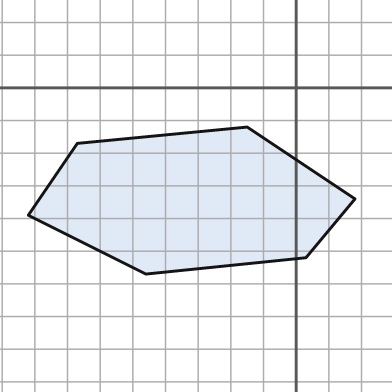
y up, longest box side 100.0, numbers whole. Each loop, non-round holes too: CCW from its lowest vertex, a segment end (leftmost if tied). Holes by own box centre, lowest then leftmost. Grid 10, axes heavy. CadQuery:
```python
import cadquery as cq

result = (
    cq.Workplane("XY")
    .moveTo(-46.0, -57.0)
    .lineTo(3.0, -52.0)
    .lineTo(18.0, -34.0)
    .lineTo(-15.0, -12.0)
    .lineTo(-67.0, -17.0)
    .lineTo(-82.0, -39.0)
    .close()
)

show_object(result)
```